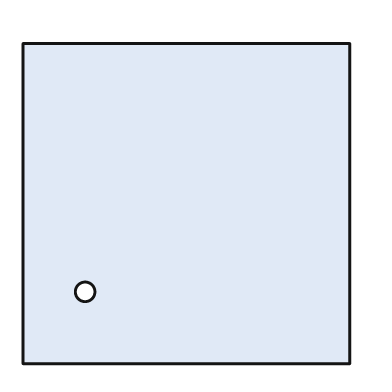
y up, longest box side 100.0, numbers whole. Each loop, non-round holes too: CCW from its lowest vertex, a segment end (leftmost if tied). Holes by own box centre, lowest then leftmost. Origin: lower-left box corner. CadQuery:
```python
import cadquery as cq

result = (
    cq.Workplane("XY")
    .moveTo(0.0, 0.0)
    .lineTo(100.0, 0.0)
    .lineTo(100.0, 98.0)
    .lineTo(0.0, 98.0)
    .close()
    .moveTo(19.0, 22.0)
    .circle(3.0)
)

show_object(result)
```